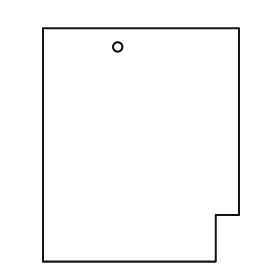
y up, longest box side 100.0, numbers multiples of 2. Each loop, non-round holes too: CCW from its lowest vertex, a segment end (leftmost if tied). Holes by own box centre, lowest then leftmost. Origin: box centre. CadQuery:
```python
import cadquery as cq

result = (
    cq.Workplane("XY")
    .moveTo(-42.0, -50.0)
    .lineTo(32.0, -50.0)
    .lineTo(32.0, -30.0)
    .lineTo(42.0, -30.0)
    .lineTo(42.0, 50.0)
    .lineTo(-42.0, 50.0)
    .close()
    .moveTo(-10.0, 42.0)
    .circle(2.0)
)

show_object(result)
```